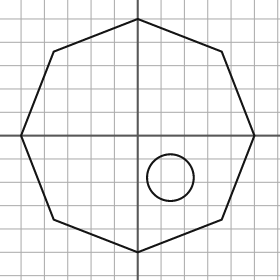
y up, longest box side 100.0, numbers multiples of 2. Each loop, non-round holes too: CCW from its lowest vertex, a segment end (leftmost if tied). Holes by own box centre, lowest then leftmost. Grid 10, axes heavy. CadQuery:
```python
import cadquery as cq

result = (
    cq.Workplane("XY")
    .moveTo(0.0, -50.0)
    .lineTo(36.0, -36.0)
    .lineTo(50.0, 0.0)
    .lineTo(36.0, 36.0)
    .lineTo(0.0, 50.0)
    .lineTo(-36.0, 36.0)
    .lineTo(-50.0, 0.0)
    .lineTo(-36.0, -36.0)
    .close()
    .moveTo(14.0, -18.0)
    .circle(10.0)
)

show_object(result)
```